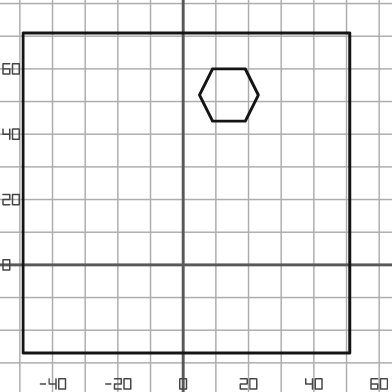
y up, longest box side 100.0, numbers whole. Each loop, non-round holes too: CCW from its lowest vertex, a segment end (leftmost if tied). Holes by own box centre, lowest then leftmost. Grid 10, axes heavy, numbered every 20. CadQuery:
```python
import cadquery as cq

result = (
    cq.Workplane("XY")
    .moveTo(-49.0, -27.0)
    .lineTo(51.0, -27.0)
    .lineTo(51.0, 71.0)
    .lineTo(-49.0, 71.0)
    .close()
    .moveTo(9.0, 44.0)
    .lineTo(19.0, 44.0)
    .lineTo(23.0, 52.0)
    .lineTo(19.0, 60.0)
    .lineTo(9.0, 60.0)
    .lineTo(5.0, 52.0)
    .close()
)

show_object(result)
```